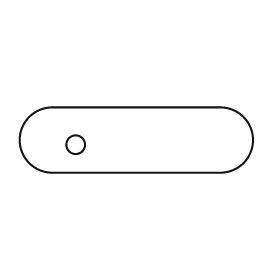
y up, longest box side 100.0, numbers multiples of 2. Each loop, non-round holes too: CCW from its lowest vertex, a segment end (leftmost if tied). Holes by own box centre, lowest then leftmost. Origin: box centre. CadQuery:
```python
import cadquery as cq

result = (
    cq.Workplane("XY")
    .moveTo(-36.0, -14.0)
    .lineTo(36.0, -14.0)
    .threePointArc((50.0, 0.0), (36.0, 14.0))
    .lineTo(-36.0, 14.0)
    .threePointArc((-50.0, 0.0), (-36.0, -14.0))
    .close()
    .moveTo(-26.0, -2.0)
    .circle(4.0)
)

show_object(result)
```